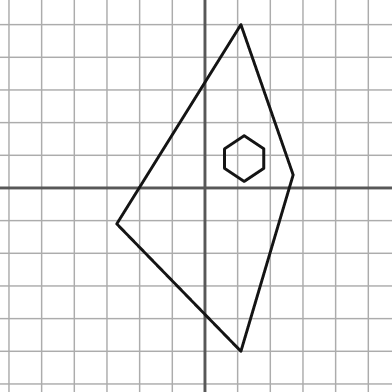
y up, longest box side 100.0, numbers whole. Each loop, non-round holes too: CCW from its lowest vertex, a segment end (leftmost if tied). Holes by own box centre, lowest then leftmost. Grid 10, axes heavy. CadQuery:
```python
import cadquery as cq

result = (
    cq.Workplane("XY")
    .moveTo(11.0, -50.0)
    .lineTo(27.0, 4.0)
    .lineTo(11.0, 50.0)
    .lineTo(-27.0, -11.0)
    .close()
    .moveTo(12.0, 2.0)
    .lineTo(18.0, 6.0)
    .lineTo(18.0, 12.0)
    .lineTo(12.0, 16.0)
    .lineTo(6.0, 12.0)
    .lineTo(6.0, 6.0)
    .close()
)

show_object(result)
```